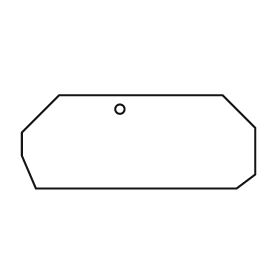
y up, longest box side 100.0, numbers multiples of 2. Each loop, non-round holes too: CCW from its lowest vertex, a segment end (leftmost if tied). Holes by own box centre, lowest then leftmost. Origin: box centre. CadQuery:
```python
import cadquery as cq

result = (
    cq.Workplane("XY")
    .moveTo(-44.0, -20.0)
    .lineTo(42.0, -20.0)
    .lineTo(50.0, -14.0)
    .lineTo(50.0, 6.0)
    .lineTo(36.0, 20.0)
    .lineTo(-34.0, 20.0)
    .lineTo(-50.0, 4.0)
    .lineTo(-50.0, -6.0)
    .close()
    .moveTo(-8.0, 14.0)
    .circle(2.0)
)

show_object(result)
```